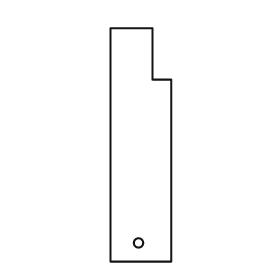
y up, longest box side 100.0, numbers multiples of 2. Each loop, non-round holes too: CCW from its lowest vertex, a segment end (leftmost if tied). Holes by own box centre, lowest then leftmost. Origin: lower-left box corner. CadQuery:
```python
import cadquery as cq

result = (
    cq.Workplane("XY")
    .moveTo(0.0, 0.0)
    .lineTo(26.0, 0.0)
    .lineTo(26.0, 78.0)
    .lineTo(18.0, 78.0)
    .lineTo(18.0, 100.0)
    .lineTo(0.0, 100.0)
    .close()
    .moveTo(12.0, 8.0)
    .circle(2.0)
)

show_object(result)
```